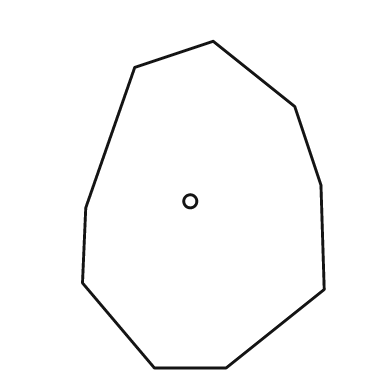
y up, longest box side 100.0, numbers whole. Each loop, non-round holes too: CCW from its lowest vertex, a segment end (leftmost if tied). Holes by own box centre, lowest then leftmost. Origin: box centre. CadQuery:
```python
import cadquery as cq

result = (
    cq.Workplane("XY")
    .moveTo(-15.0, -50.0)
    .lineTo(7.0, -50.0)
    .lineTo(37.0, -26.0)
    .lineTo(36.0, 6.0)
    .lineTo(28.0, 30.0)
    .lineTo(3.0, 50.0)
    .lineTo(-21.0, 42.0)
    .lineTo(-36.0, -1.0)
    .lineTo(-37.0, -24.0)
    .close()
    .moveTo(-4.0, 1.0)
    .circle(2.0)
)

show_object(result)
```